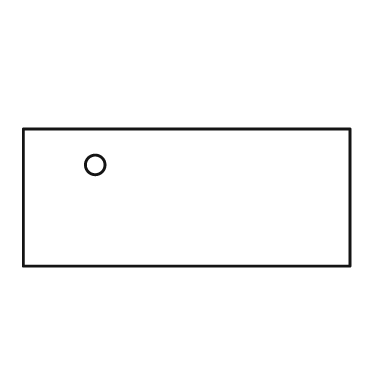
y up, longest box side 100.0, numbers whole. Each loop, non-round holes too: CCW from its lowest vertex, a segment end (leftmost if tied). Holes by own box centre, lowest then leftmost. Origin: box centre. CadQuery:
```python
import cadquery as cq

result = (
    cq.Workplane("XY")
    .moveTo(-50.0, -21.0)
    .lineTo(50.0, -21.0)
    .lineTo(50.0, 21.0)
    .lineTo(-50.0, 21.0)
    .close()
    .moveTo(-28.0, 10.0)
    .circle(3.0)
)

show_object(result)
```